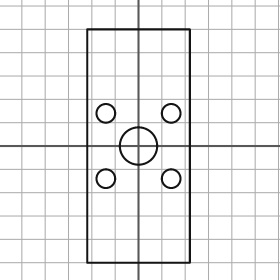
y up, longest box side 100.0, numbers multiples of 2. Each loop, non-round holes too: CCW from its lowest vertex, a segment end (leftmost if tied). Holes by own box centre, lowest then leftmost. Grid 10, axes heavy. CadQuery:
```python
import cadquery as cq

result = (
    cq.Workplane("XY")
    .moveTo(-22.0, -50.0)
    .lineTo(22.0, -50.0)
    .lineTo(22.0, 50.0)
    .lineTo(-22.0, 50.0)
    .close()
    .moveTo(-14.0, -14.0)
    .circle(4.0)
    .moveTo(14.0, -14.0)
    .circle(4.0)
    .moveTo(0.0, 0.0)
    .circle(8.0)
    .moveTo(-14.0, 14.0)
    .circle(4.0)
    .moveTo(14.0, 14.0)
    .circle(4.0)
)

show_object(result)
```